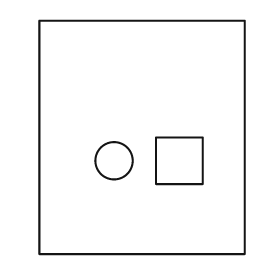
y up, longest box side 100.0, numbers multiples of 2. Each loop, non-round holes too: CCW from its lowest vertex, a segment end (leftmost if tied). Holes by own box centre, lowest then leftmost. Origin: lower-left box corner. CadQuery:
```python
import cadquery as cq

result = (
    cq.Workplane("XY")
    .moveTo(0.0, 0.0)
    .lineTo(88.0, 0.0)
    .lineTo(88.0, 100.0)
    .lineTo(0.0, 100.0)
    .close()
    .moveTo(32.0, 40.0)
    .circle(8.0)
    .moveTo(50.0, 30.0)
    .lineTo(70.0, 30.0)
    .lineTo(70.0, 50.0)
    .lineTo(50.0, 50.0)
    .close()
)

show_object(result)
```